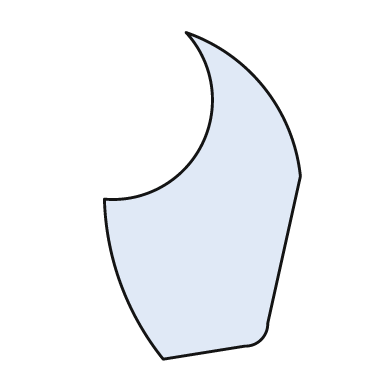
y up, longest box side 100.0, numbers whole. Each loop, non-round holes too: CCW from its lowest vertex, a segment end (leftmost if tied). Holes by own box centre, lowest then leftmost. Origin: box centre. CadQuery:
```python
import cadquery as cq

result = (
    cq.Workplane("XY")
    .moveTo(-12.0, -50.0)
    .lineTo(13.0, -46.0)
    .threePointArc((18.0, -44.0), (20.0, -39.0))
    .lineTo(30.0, 6.0)
    .threePointArc((19.0, 33.0), (-5.0, 50.0))
    .threePointArc((0.0, 16.0), (-30.0, -1.0))
    .threePointArc((-25.0, -27.0), (-12.0, -50.0))
    .close()
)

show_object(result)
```